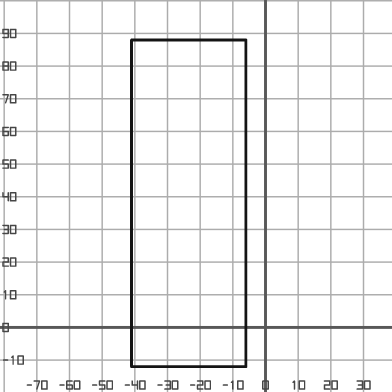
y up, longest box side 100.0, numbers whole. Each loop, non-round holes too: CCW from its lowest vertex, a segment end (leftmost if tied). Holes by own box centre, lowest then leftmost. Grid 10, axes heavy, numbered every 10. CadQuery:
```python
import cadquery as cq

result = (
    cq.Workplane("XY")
    .moveTo(-41.0, -12.0)
    .lineTo(-6.0, -12.0)
    .lineTo(-6.0, 88.0)
    .lineTo(-41.0, 88.0)
    .close()
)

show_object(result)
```